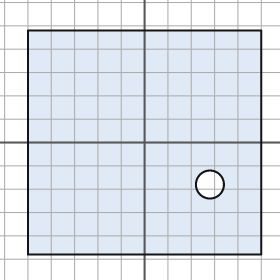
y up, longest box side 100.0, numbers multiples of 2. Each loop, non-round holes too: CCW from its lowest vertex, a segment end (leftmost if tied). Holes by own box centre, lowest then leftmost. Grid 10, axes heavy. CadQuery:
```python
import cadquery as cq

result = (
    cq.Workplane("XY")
    .moveTo(-50.0, -48.0)
    .lineTo(50.0, -48.0)
    .lineTo(50.0, 48.0)
    .lineTo(-50.0, 48.0)
    .close()
    .moveTo(28.0, -18.0)
    .circle(6.0)
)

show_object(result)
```